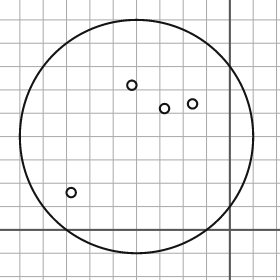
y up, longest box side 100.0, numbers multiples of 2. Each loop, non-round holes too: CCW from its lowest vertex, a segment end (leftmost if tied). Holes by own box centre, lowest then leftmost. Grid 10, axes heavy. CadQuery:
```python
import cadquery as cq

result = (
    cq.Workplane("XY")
    .moveTo(-40.0, 40.0)
    .circle(50.0)
    .moveTo(-68.0, 16.0)
    .circle(2.0)
    .moveTo(-28.0, 52.0)
    .circle(2.0)
    .moveTo(-16.0, 54.0)
    .circle(2.0)
    .moveTo(-42.0, 62.0)
    .circle(2.0)
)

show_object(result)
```